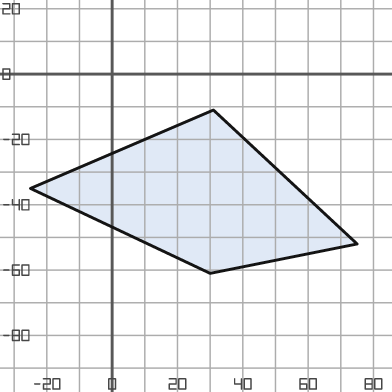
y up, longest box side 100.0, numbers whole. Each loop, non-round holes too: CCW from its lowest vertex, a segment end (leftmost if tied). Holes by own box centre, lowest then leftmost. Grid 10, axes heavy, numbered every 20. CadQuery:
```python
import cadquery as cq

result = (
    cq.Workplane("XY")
    .moveTo(30.0, -61.0)
    .lineTo(75.0, -52.0)
    .lineTo(31.0, -11.0)
    .lineTo(-25.0, -35.0)
    .close()
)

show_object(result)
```